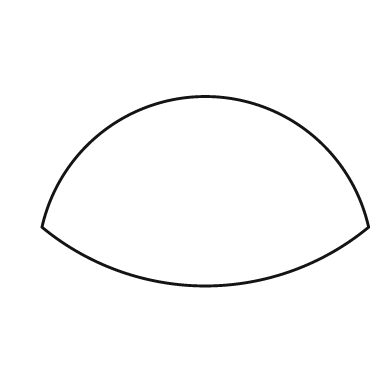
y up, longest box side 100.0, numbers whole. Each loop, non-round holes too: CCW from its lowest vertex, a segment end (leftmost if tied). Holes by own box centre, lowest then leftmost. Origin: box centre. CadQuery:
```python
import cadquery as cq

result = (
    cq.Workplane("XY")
    .moveTo(-50.0, -11.0)
    .threePointArc((0.0, -29.0), (50.0, -11.0))
    .threePointArc((0.0, 29.0), (-50.0, -11.0))
    .close()
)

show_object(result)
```